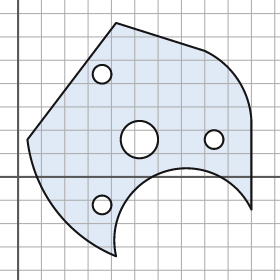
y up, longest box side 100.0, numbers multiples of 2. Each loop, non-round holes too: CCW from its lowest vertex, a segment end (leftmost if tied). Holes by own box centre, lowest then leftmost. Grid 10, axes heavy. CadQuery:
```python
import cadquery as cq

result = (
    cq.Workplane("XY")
    .moveTo(42.0, -34.0)
    .threePointArc((62.0, 2.0), (100.0, -14.0))
    .lineTo(100.0, 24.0)
    .threePointArc((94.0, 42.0), (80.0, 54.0))
    .lineTo(42.0, 66.0)
    .lineTo(4.0, 16.0)
    .threePointArc((16.0, -14.0), (42.0, -34.0))
    .close()
    .moveTo(36.0, -12.0)
    .circle(4.0)
    .moveTo(52.0, 16.0)
    .circle(8.0)
    .moveTo(84.0, 16.0)
    .circle(4.0)
    .moveTo(36.0, 44.0)
    .circle(4.0)
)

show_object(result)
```